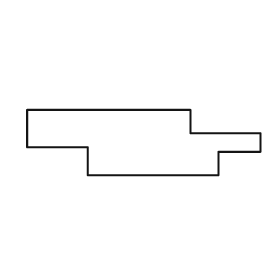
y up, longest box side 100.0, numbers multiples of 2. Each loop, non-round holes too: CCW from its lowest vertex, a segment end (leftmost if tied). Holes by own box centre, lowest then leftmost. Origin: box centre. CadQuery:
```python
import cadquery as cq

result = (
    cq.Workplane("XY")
    .moveTo(-24.0, -14.0)
    .lineTo(32.0, -14.0)
    .lineTo(32.0, -4.0)
    .lineTo(50.0, -4.0)
    .lineTo(50.0, 4.0)
    .lineTo(20.0, 4.0)
    .lineTo(20.0, 14.0)
    .lineTo(-50.0, 14.0)
    .lineTo(-50.0, -2.0)
    .lineTo(-24.0, -2.0)
    .close()
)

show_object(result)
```